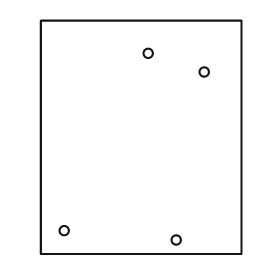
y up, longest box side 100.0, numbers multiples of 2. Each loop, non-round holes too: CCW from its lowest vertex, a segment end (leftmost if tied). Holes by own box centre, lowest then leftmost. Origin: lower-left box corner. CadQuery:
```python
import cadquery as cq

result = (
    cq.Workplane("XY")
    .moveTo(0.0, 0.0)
    .lineTo(86.0, 0.0)
    .lineTo(86.0, 100.0)
    .lineTo(0.0, 100.0)
    .close()
    .moveTo(58.0, 6.0)
    .circle(2.0)
    .moveTo(10.0, 10.0)
    .circle(2.0)
    .moveTo(70.0, 78.0)
    .circle(2.0)
    .moveTo(46.0, 86.0)
    .circle(2.0)
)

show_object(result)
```